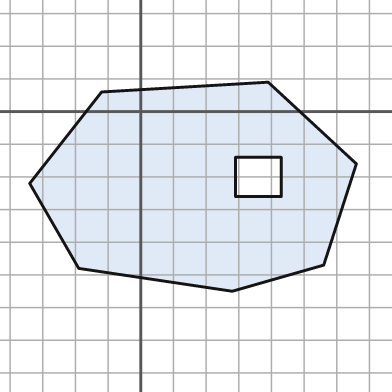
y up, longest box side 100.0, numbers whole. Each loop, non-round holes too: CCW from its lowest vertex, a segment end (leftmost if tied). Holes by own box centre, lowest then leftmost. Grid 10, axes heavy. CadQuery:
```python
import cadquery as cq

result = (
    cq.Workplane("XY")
    .moveTo(28.0, -55.0)
    .lineTo(56.0, -47.0)
    .lineTo(66.0, -16.0)
    .lineTo(39.0, 9.0)
    .lineTo(-12.0, 6.0)
    .lineTo(-34.0, -22.0)
    .lineTo(-19.0, -48.0)
    .close()
    .moveTo(29.0, -26.0)
    .lineTo(43.0, -26.0)
    .lineTo(43.0, -14.0)
    .lineTo(29.0, -14.0)
    .close()
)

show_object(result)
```